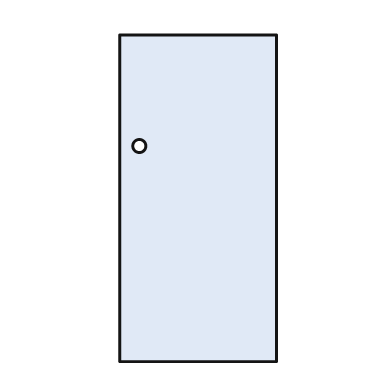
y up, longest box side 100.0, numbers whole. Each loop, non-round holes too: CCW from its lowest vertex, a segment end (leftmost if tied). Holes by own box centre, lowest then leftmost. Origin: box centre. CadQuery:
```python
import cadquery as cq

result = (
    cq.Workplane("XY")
    .moveTo(-24.0, -50.0)
    .lineTo(24.0, -50.0)
    .lineTo(24.0, 50.0)
    .lineTo(-24.0, 50.0)
    .close()
    .moveTo(-18.0, 16.0)
    .circle(2.0)
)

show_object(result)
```